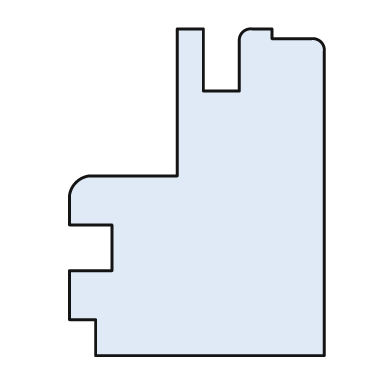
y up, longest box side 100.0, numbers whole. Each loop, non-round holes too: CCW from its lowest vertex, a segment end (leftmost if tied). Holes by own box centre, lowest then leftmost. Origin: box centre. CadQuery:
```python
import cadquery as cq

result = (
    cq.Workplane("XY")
    .moveTo(-31.0, -50.0)
    .lineTo(39.0, -50.0)
    .lineTo(39.0, 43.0)
    .threePointArc((38.0, 46.0), (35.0, 47.0))
    .lineTo(23.0, 47.0)
    .lineTo(23.0, 50.0)
    .lineTo(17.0, 50.0)
    .threePointArc((14.0, 49.0), (13.0, 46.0))
    .lineTo(13.0, 31.0)
    .lineTo(2.0, 31.0)
    .lineTo(2.0, 50.0)
    .lineTo(-6.0, 50.0)
    .lineTo(-6.0, 5.0)
    .lineTo(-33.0, 5.0)
    .threePointArc((-37.0, 3.0), (-39.0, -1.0))
    .lineTo(-39.0, -10.0)
    .lineTo(-26.0, -10.0)
    .lineTo(-26.0, -24.0)
    .lineTo(-39.0, -24.0)
    .lineTo(-39.0, -39.0)
    .lineTo(-31.0, -39.0)
    .close()
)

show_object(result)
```